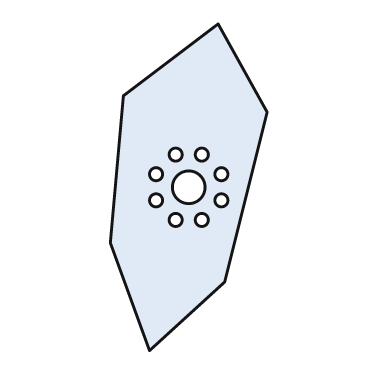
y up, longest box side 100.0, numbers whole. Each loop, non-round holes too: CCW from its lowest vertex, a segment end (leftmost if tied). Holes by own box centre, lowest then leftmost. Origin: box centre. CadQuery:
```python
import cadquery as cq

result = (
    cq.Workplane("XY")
    .moveTo(-12.0, -50.0)
    .lineTo(11.0, -29.0)
    .lineTo(24.0, 23.0)
    .lineTo(9.0, 50.0)
    .lineTo(-20.0, 28.0)
    .lineTo(-24.0, -17.0)
    .close()
    .moveTo(-4.0, -10.0)
    .circle(2.0)
    .moveTo(4.0, -10.0)
    .circle(2.0)
    .moveTo(-10.0, -4.0)
    .circle(2.0)
    .moveTo(10.0, -4.0)
    .circle(2.0)
    .moveTo(0.0, 0.0)
    .circle(5.0)
    .moveTo(-10.0, 4.0)
    .circle(2.0)
    .moveTo(10.0, 4.0)
    .circle(2.0)
    .moveTo(-4.0, 10.0)
    .circle(2.0)
    .moveTo(4.0, 10.0)
    .circle(2.0)
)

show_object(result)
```